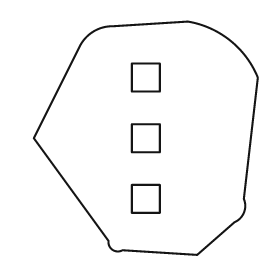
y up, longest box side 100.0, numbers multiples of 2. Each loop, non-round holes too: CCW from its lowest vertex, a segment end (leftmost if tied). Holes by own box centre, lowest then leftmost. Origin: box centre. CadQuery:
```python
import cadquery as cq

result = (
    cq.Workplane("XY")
    .moveTo(22.0, -50.0)
    .lineTo(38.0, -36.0)
    .threePointArc((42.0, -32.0), (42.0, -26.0))
    .lineTo(48.0, 26.0)
    .threePointArc((36.0, 42.0), (18.0, 50.0))
    .lineTo(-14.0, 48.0)
    .threePointArc((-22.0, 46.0), (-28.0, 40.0))
    .lineTo(-48.0, 0.0)
    .lineTo(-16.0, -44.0)
    .threePointArc((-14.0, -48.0), (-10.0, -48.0))
    .close()
    .moveTo(-6.0, -32.0)
    .lineTo(6.0, -32.0)
    .lineTo(6.0, -20.0)
    .lineTo(-6.0, -20.0)
    .close()
    .moveTo(-6.0, -6.0)
    .lineTo(6.0, -6.0)
    .lineTo(6.0, 6.0)
    .lineTo(-6.0, 6.0)
    .close()
    .moveTo(-6.0, 20.0)
    .lineTo(6.0, 20.0)
    .lineTo(6.0, 32.0)
    .lineTo(-6.0, 32.0)
    .close()
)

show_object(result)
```